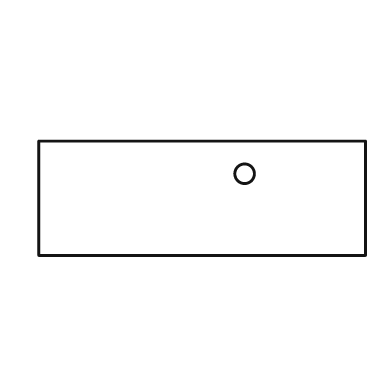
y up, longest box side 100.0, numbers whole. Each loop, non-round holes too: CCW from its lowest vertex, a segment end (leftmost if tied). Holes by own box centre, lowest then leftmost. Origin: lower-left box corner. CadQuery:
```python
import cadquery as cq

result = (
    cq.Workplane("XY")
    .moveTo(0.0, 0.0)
    .lineTo(100.0, 0.0)
    .lineTo(100.0, 35.0)
    .lineTo(0.0, 35.0)
    .close()
    .moveTo(63.0, 25.0)
    .circle(3.0)
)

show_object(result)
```